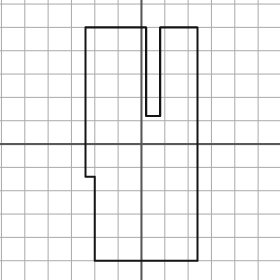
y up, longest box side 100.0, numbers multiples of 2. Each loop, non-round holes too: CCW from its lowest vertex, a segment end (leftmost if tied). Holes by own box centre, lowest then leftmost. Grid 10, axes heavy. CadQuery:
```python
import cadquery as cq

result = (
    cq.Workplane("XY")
    .moveTo(-20.0, -50.0)
    .lineTo(24.0, -50.0)
    .lineTo(24.0, 50.0)
    .lineTo(8.0, 50.0)
    .lineTo(8.0, 12.0)
    .lineTo(2.0, 12.0)
    .lineTo(2.0, 50.0)
    .lineTo(-24.0, 50.0)
    .lineTo(-24.0, -14.0)
    .lineTo(-20.0, -14.0)
    .close()
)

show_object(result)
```